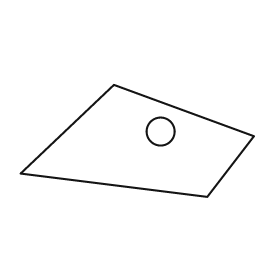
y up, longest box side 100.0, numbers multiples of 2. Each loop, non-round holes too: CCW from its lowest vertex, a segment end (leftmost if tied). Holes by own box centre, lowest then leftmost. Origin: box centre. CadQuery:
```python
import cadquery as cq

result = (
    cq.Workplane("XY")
    .moveTo(30.0, -24.0)
    .lineTo(50.0, 2.0)
    .lineTo(-10.0, 24.0)
    .lineTo(-50.0, -14.0)
    .close()
    .moveTo(10.0, 4.0)
    .circle(6.0)
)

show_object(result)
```